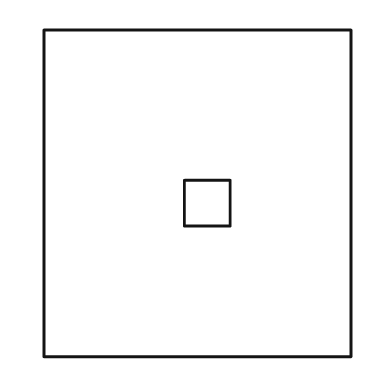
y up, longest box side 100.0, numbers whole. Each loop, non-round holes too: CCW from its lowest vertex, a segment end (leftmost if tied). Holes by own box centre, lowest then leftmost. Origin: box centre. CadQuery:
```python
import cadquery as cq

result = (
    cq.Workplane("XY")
    .moveTo(-47.0, -50.0)
    .lineTo(47.0, -50.0)
    .lineTo(47.0, 50.0)
    .lineTo(-47.0, 50.0)
    .close()
    .moveTo(-4.0, -10.0)
    .lineTo(10.0, -10.0)
    .lineTo(10.0, 4.0)
    .lineTo(-4.0, 4.0)
    .close()
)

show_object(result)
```